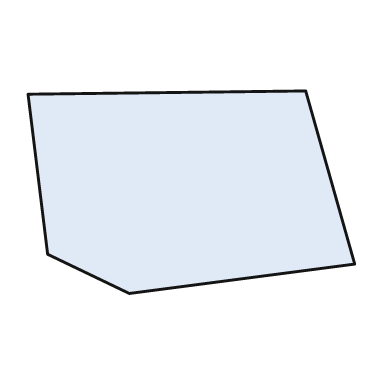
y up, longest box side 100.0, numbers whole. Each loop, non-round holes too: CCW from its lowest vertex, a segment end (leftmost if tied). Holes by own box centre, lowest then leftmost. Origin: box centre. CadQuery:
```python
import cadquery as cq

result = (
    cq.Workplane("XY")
    .moveTo(-19.0, -31.0)
    .lineTo(50.0, -22.0)
    .lineTo(35.0, 31.0)
    .lineTo(-50.0, 30.0)
    .lineTo(-44.0, -19.0)
    .close()
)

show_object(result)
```